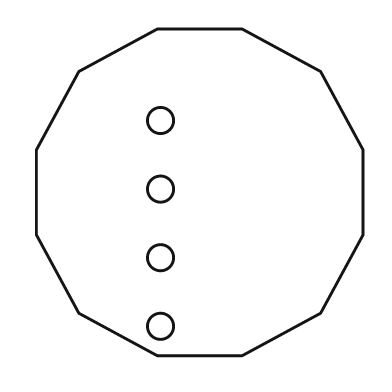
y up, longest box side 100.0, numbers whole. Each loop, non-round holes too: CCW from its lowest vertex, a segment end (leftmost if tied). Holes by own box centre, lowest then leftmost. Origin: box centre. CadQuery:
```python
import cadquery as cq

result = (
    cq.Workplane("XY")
    .moveTo(-13.0, -50.0)
    .lineTo(13.0, -50.0)
    .lineTo(37.0, -37.0)
    .lineTo(50.0, -13.0)
    .lineTo(50.0, 13.0)
    .lineTo(37.0, 37.0)
    .lineTo(13.0, 50.0)
    .lineTo(-13.0, 50.0)
    .lineTo(-37.0, 37.0)
    .lineTo(-50.0, 13.0)
    .lineTo(-50.0, -13.0)
    .lineTo(-37.0, -37.0)
    .close()
    .moveTo(-12.0, -41.0)
    .circle(4.0)
    .moveTo(-12.0, -20.0)
    .circle(4.0)
    .moveTo(-12.0, 1.0)
    .circle(4.0)
    .moveTo(-12.0, 22.0)
    .circle(4.0)
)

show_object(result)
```